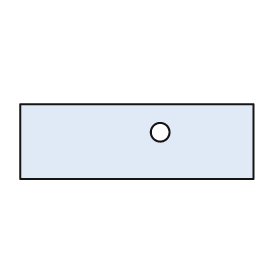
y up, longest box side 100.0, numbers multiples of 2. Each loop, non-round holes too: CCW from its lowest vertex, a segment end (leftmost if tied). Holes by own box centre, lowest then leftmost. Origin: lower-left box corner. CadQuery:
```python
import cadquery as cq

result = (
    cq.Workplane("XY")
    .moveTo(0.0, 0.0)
    .lineTo(100.0, 0.0)
    .lineTo(100.0, 32.0)
    .lineTo(0.0, 32.0)
    .close()
    .moveTo(60.0, 20.0)
    .circle(4.0)
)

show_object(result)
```